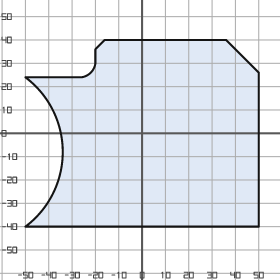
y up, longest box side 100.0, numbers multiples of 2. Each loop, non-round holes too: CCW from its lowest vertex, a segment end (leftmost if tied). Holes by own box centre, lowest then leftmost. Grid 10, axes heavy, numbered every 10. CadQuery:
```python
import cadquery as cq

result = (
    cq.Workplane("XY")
    .moveTo(-50.0, -40.0)
    .lineTo(50.0, -40.0)
    .lineTo(50.0, 26.0)
    .lineTo(36.0, 40.0)
    .lineTo(-16.0, 40.0)
    .lineTo(-20.0, 36.0)
    .lineTo(-20.0, 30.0)
    .threePointArc((-22.0, 26.0), (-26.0, 24.0))
    .lineTo(-50.0, 24.0)
    .threePointArc((-34.0, -8.0), (-50.0, -40.0))
    .close()
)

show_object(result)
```